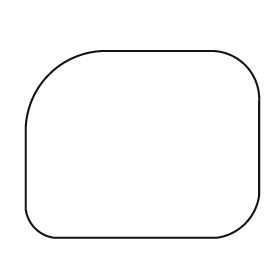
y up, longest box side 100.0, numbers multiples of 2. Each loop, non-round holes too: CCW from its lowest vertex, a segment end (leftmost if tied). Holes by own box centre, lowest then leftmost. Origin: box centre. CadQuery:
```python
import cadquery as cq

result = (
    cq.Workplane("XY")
    .moveTo(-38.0, -40.0)
    .lineTo(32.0, -40.0)
    .threePointArc((44.0, -34.0), (50.0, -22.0))
    .lineTo(50.0, 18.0)
    .threePointArc((44.0, 34.0), (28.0, 40.0))
    .lineTo(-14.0, 40.0)
    .threePointArc((-40.0, 30.0), (-50.0, 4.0))
    .lineTo(-50.0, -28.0)
    .threePointArc((-46.0, -36.0), (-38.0, -40.0))
    .close()
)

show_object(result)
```